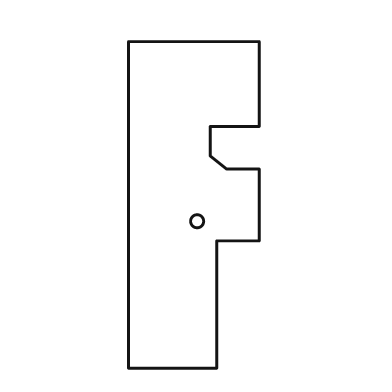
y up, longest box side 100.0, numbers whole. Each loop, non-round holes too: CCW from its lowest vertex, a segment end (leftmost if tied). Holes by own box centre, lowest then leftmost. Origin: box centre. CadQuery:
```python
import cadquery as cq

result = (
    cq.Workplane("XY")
    .moveTo(-20.0, -50.0)
    .lineTo(7.0, -50.0)
    .lineTo(7.0, -11.0)
    .lineTo(20.0, -11.0)
    .lineTo(20.0, 11.0)
    .lineTo(10.0, 11.0)
    .lineTo(5.0, 15.0)
    .lineTo(5.0, 24.0)
    .lineTo(20.0, 24.0)
    .lineTo(20.0, 50.0)
    .lineTo(-20.0, 50.0)
    .close()
    .moveTo(1.0, -5.0)
    .circle(2.0)
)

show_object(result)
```